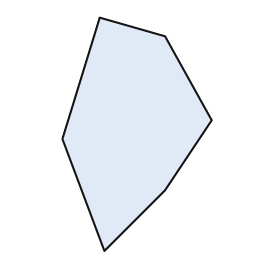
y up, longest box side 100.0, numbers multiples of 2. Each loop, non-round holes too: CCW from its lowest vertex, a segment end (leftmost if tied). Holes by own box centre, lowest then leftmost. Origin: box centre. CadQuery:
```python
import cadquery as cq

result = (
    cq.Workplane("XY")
    .moveTo(-14.0, -50.0)
    .lineTo(12.0, -24.0)
    .lineTo(32.0, 6.0)
    .lineTo(12.0, 42.0)
    .lineTo(-16.0, 50.0)
    .lineTo(-32.0, -2.0)
    .close()
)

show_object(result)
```